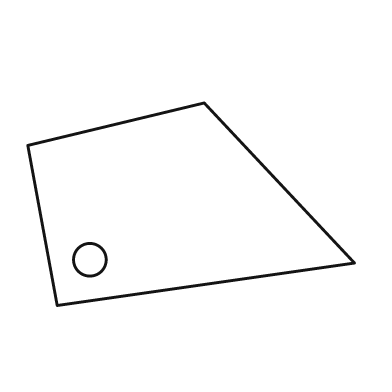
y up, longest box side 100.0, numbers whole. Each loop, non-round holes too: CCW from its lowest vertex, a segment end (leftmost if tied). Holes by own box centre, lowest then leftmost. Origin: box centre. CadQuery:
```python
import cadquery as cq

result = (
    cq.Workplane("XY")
    .moveTo(-41.0, -31.0)
    .lineTo(50.0, -18.0)
    .lineTo(4.0, 31.0)
    .lineTo(-50.0, 18.0)
    .close()
    .moveTo(-31.0, -17.0)
    .circle(5.0)
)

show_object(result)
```